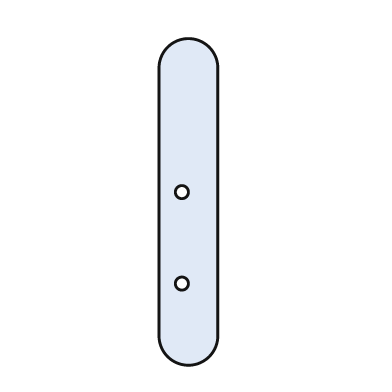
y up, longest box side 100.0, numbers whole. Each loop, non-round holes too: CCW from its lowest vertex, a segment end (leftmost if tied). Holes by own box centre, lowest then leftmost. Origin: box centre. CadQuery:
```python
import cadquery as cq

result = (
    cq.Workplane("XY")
    .moveTo(-9.0, -41.0)
    .threePointArc((0.0, -50.0), (9.0, -41.0))
    .lineTo(9.0, 41.0)
    .threePointArc((0.0, 50.0), (-9.0, 41.0))
    .close()
    .moveTo(-2.0, -25.0)
    .circle(2.0)
    .moveTo(-2.0, 3.0)
    .circle(2.0)
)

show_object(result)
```